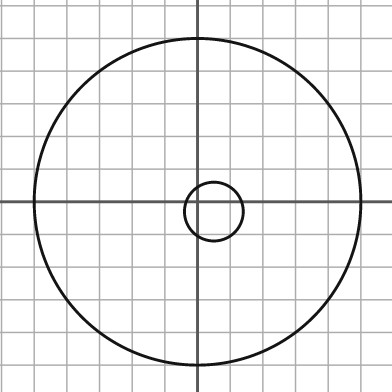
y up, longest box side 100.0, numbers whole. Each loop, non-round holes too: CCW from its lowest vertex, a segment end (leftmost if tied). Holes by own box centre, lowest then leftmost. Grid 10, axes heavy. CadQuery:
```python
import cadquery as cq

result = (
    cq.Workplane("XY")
    .moveTo(0.0, 0.0)
    .circle(50.0)
    .moveTo(5.0, -3.0)
    .circle(9.0)
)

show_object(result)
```